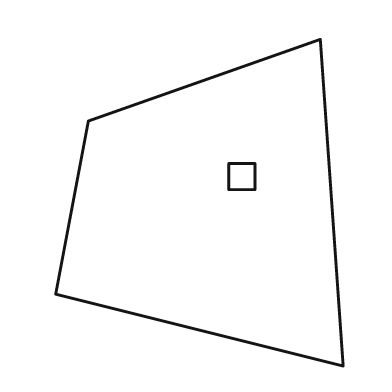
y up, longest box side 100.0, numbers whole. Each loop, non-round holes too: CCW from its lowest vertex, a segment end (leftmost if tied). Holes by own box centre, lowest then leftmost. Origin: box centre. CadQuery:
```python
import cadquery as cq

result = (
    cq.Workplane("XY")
    .moveTo(44.0, -50.0)
    .lineTo(37.0, 50.0)
    .lineTo(-34.0, 25.0)
    .lineTo(-44.0, -28.0)
    .close()
    .moveTo(9.0, 4.0)
    .lineTo(17.0, 4.0)
    .lineTo(17.0, 12.0)
    .lineTo(9.0, 12.0)
    .close()
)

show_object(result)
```